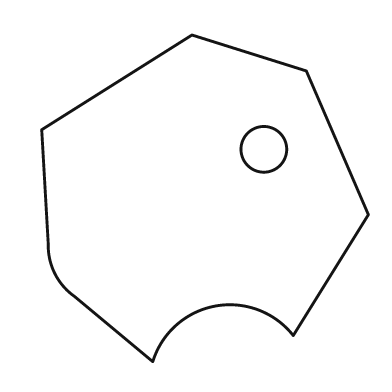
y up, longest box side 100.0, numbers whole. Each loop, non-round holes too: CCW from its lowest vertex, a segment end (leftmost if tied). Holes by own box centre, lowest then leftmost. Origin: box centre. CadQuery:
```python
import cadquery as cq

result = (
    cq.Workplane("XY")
    .moveTo(-16.0, -50.0)
    .threePointArc((3.0, -33.0), (27.0, -42.0))
    .lineTo(50.0, -5.0)
    .lineTo(31.0, 39.0)
    .lineTo(-4.0, 50.0)
    .lineTo(-50.0, 21.0)
    .lineTo(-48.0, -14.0)
    .threePointArc((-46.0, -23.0), (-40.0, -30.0))
    .close()
    .moveTo(18.0, 15.0)
    .circle(7.0)
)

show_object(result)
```